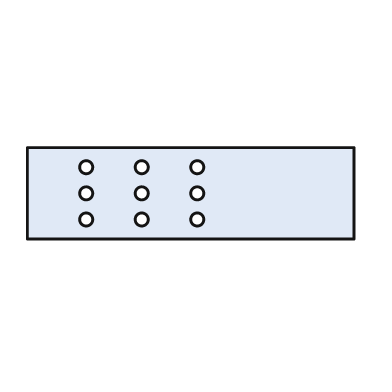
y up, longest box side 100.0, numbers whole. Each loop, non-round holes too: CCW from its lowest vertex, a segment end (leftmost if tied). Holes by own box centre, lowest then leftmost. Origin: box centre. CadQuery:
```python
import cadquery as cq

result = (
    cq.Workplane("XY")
    .moveTo(-50.0, -14.0)
    .lineTo(50.0, -14.0)
    .lineTo(50.0, 14.0)
    .lineTo(-50.0, 14.0)
    .close()
    .moveTo(-32.0, -8.0)
    .circle(2.0)
    .moveTo(-15.0, -8.0)
    .circle(2.0)
    .moveTo(2.0, -8.0)
    .circle(2.0)
    .moveTo(-32.0, 0.0)
    .circle(2.0)
    .moveTo(-15.0, 0.0)
    .circle(2.0)
    .moveTo(2.0, 0.0)
    .circle(2.0)
    .moveTo(-32.0, 8.0)
    .circle(2.0)
    .moveTo(-15.0, 8.0)
    .circle(2.0)
    .moveTo(2.0, 8.0)
    .circle(2.0)
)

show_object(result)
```